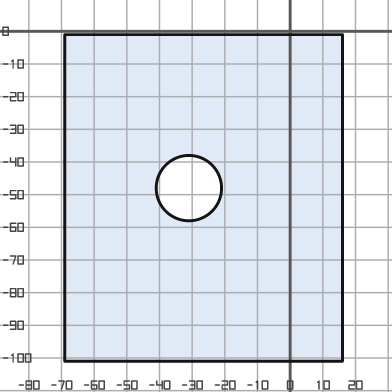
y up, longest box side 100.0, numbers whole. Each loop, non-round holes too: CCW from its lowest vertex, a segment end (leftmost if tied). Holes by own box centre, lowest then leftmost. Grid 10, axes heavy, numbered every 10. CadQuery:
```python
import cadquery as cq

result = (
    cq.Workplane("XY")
    .moveTo(-69.0, -101.0)
    .lineTo(16.0, -101.0)
    .lineTo(16.0, -1.0)
    .lineTo(-69.0, -1.0)
    .close()
    .moveTo(-31.0, -48.0)
    .circle(10.0)
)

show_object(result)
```